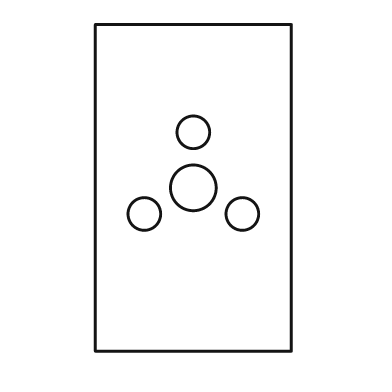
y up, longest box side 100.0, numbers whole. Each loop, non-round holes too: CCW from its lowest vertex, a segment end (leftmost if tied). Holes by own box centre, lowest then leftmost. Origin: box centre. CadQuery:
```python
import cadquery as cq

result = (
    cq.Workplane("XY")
    .moveTo(-30.0, -50.0)
    .lineTo(30.0, -50.0)
    .lineTo(30.0, 50.0)
    .lineTo(-30.0, 50.0)
    .close()
    .moveTo(-15.0, -8.0)
    .circle(5.0)
    .moveTo(15.0, -8.0)
    .circle(5.0)
    .moveTo(0.0, 0.0)
    .circle(7.0)
    .moveTo(0.0, 17.0)
    .circle(5.0)
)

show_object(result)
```